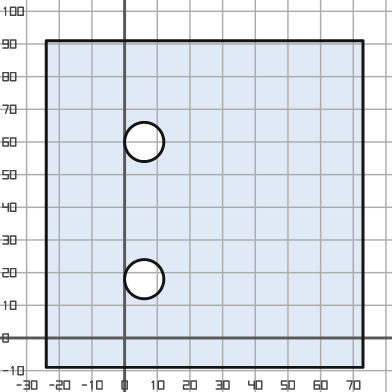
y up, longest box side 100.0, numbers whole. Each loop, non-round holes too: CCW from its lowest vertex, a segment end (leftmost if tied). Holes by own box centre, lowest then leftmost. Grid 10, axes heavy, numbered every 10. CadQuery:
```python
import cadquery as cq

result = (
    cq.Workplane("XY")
    .moveTo(-24.0, -9.0)
    .lineTo(73.0, -9.0)
    .lineTo(73.0, 91.0)
    .lineTo(-24.0, 91.0)
    .close()
    .moveTo(6.0, 18.0)
    .circle(6.0)
    .moveTo(6.0, 60.0)
    .circle(6.0)
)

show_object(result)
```